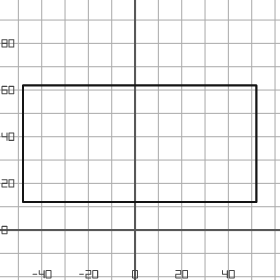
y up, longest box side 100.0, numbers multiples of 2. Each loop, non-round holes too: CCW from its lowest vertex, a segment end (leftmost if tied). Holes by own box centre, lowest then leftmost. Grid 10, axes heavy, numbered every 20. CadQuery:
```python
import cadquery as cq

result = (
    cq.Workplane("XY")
    .moveTo(-48.0, 12.0)
    .lineTo(52.0, 12.0)
    .lineTo(52.0, 62.0)
    .lineTo(-48.0, 62.0)
    .close()
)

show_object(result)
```